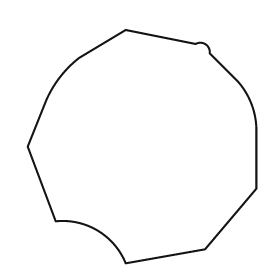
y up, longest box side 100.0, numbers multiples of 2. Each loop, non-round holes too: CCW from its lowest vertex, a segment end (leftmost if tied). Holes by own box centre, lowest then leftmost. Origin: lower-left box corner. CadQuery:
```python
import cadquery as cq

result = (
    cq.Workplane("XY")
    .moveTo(42.0, 0.0)
    .lineTo(76.0, 6.0)
    .lineTo(98.0, 32.0)
    .lineTo(98.0, 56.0)
    .threePointArc((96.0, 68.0), (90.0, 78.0))
    .lineTo(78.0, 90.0)
    .threePointArc((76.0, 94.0), (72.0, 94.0))
    .lineTo(42.0, 100.0)
    .lineTo(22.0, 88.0)
    .threePointArc((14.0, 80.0), (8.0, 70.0))
    .lineTo(0.0, 50.0)
    .lineTo(12.0, 18.0)
    .threePointArc((30.0, 14.0), (42.0, 0.0))
    .close()
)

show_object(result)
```